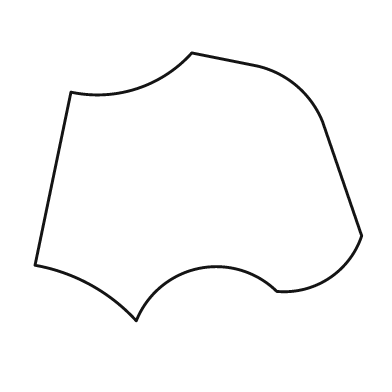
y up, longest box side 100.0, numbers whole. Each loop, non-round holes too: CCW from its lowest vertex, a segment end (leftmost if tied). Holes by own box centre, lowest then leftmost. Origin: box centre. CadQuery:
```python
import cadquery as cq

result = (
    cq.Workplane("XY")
    .moveTo(-19.0, -41.0)
    .threePointArc((0.0, -25.0), (24.0, -32.0))
    .threePointArc((40.0, -28.0), (50.0, -15.0))
    .lineTo(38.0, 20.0)
    .threePointArc((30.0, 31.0), (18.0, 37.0))
    .lineTo(-2.0, 41.0)
    .threePointArc((-19.0, 30.0), (-39.0, 29.0))
    .lineTo(-50.0, -24.0)
    .threePointArc((-33.0, -30.0), (-19.0, -41.0))
    .close()
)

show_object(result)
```